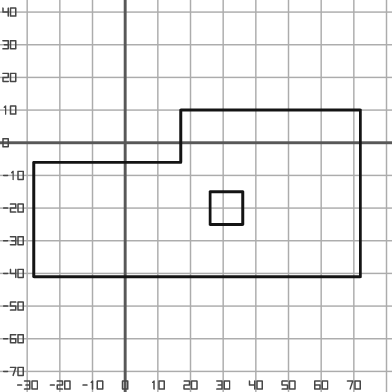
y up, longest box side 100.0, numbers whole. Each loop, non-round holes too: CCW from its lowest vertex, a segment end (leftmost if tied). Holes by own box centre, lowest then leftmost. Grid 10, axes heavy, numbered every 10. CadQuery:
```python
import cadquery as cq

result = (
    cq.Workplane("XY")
    .moveTo(-28.0, -41.0)
    .lineTo(72.0, -41.0)
    .lineTo(72.0, 10.0)
    .lineTo(17.0, 10.0)
    .lineTo(17.0, -6.0)
    .lineTo(-28.0, -6.0)
    .close()
    .moveTo(26.0, -25.0)
    .lineTo(36.0, -25.0)
    .lineTo(36.0, -15.0)
    .lineTo(26.0, -15.0)
    .close()
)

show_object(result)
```